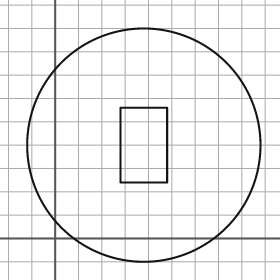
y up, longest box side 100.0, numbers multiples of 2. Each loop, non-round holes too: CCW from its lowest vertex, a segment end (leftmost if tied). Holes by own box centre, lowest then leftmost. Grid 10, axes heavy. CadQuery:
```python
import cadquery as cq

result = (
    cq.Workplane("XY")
    .moveTo(38.0, 40.0)
    .circle(50.0)
    .moveTo(28.0, 24.0)
    .lineTo(48.0, 24.0)
    .lineTo(48.0, 56.0)
    .lineTo(28.0, 56.0)
    .close()
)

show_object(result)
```